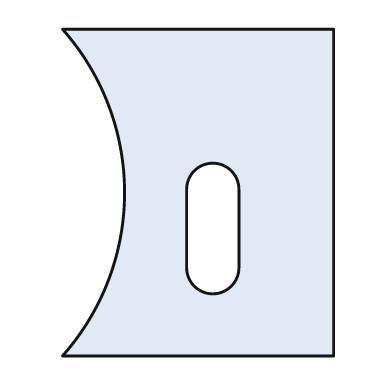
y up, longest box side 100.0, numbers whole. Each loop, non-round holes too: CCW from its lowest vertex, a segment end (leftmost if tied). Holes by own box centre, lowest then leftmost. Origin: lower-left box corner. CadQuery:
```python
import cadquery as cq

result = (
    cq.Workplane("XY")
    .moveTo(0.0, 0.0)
    .lineTo(83.0, 0.0)
    .lineTo(83.0, 100.0)
    .lineTo(0.0, 100.0)
    .threePointArc((19.0, 50.0), (0.0, 0.0))
    .close()
    .moveTo(38.0, 27.0)
    .threePointArc((46.0, 19.0), (54.0, 27.0))
    .lineTo(54.0, 51.0)
    .threePointArc((46.0, 59.0), (38.0, 51.0))
    .close()
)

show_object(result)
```